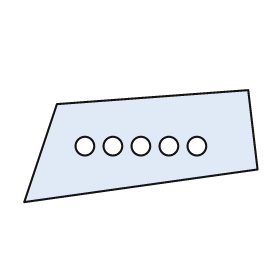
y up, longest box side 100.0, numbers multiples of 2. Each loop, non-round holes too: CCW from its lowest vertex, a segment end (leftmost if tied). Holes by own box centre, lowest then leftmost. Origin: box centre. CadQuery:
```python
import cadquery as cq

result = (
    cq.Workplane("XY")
    .moveTo(-50.0, -24.0)
    .lineTo(50.0, -10.0)
    .lineTo(46.0, 24.0)
    .lineTo(-36.0, 18.0)
    .close()
    .moveTo(-24.0, 0.0)
    .circle(4.0)
    .moveTo(-12.0, 0.0)
    .circle(4.0)
    .moveTo(0.0, 0.0)
    .circle(4.0)
    .moveTo(12.0, 0.0)
    .circle(4.0)
    .moveTo(24.0, 0.0)
    .circle(4.0)
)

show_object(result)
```